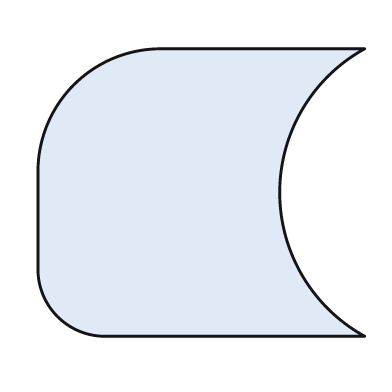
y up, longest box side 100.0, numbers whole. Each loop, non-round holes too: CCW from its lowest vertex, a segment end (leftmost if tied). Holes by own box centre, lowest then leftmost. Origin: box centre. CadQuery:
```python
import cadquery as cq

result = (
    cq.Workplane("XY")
    .moveTo(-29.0, -44.0)
    .lineTo(50.0, -44.0)
    .threePointArc((24.0, 0.0), (50.0, 44.0))
    .lineTo(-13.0, 44.0)
    .threePointArc((-39.0, 33.0), (-50.0, 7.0))
    .lineTo(-50.0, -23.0)
    .threePointArc((-44.0, -38.0), (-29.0, -44.0))
    .close()
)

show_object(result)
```